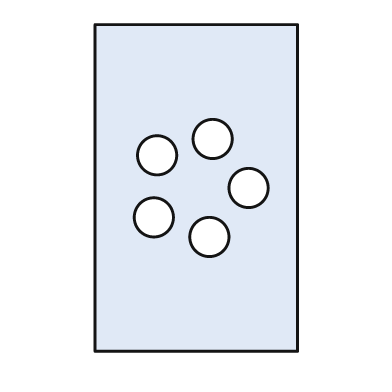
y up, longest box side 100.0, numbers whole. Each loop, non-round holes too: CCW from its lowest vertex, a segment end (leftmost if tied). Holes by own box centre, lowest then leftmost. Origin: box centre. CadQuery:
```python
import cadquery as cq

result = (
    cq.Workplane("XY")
    .moveTo(-31.0, -50.0)
    .lineTo(31.0, -50.0)
    .lineTo(31.0, 50.0)
    .lineTo(-31.0, 50.0)
    .close()
    .moveTo(4.0, -15.0)
    .circle(6.0)
    .moveTo(-13.0, -9.0)
    .circle(6.0)
    .moveTo(16.0, 0.0)
    .circle(6.0)
    .moveTo(-12.0, 10.0)
    .circle(6.0)
    .moveTo(5.0, 15.0)
    .circle(6.0)
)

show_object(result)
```